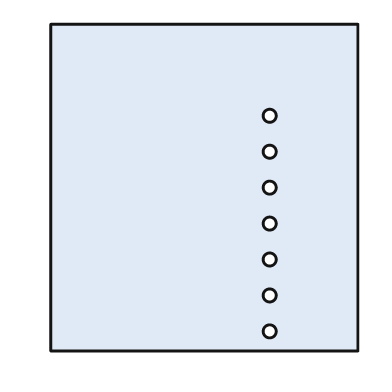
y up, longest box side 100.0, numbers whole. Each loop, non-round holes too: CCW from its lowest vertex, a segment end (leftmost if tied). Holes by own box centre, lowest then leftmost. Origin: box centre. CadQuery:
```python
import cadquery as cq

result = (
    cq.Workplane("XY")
    .moveTo(-47.0, -50.0)
    .lineTo(47.0, -50.0)
    .lineTo(47.0, 50.0)
    .lineTo(-47.0, 50.0)
    .close()
    .moveTo(20.0, -44.0)
    .circle(2.0)
    .moveTo(20.0, -33.0)
    .circle(2.0)
    .moveTo(20.0, -22.0)
    .circle(2.0)
    .moveTo(20.0, -11.0)
    .circle(2.0)
    .moveTo(20.0, 0.0)
    .circle(2.0)
    .moveTo(20.0, 11.0)
    .circle(2.0)
    .moveTo(20.0, 22.0)
    .circle(2.0)
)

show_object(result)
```